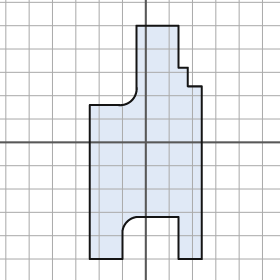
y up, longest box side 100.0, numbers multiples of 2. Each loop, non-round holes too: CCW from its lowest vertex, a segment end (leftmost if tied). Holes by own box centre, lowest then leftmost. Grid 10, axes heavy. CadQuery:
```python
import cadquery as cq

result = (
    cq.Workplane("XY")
    .moveTo(-24.0, -50.0)
    .lineTo(-10.0, -50.0)
    .lineTo(-10.0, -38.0)
    .threePointArc((-8.0, -34.0), (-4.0, -32.0))
    .lineTo(14.0, -32.0)
    .lineTo(14.0, -50.0)
    .lineTo(24.0, -50.0)
    .lineTo(24.0, 24.0)
    .lineTo(18.0, 24.0)
    .lineTo(18.0, 32.0)
    .lineTo(14.0, 32.0)
    .lineTo(14.0, 50.0)
    .lineTo(-4.0, 50.0)
    .lineTo(-4.0, 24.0)
    .threePointArc((-6.0, 18.0), (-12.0, 16.0))
    .lineTo(-24.0, 16.0)
    .close()
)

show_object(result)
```